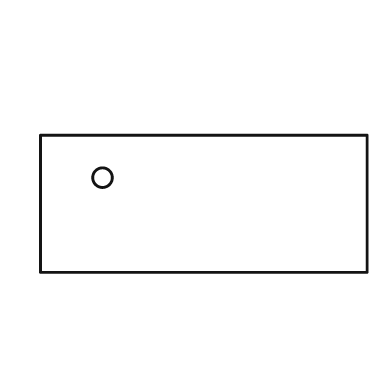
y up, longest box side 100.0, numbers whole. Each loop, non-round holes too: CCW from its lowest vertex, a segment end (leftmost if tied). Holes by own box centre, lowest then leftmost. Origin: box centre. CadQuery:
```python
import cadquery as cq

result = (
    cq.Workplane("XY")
    .moveTo(-50.0, -21.0)
    .lineTo(50.0, -21.0)
    .lineTo(50.0, 21.0)
    .lineTo(-50.0, 21.0)
    .close()
    .moveTo(-31.0, 8.0)
    .circle(3.0)
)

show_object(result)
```